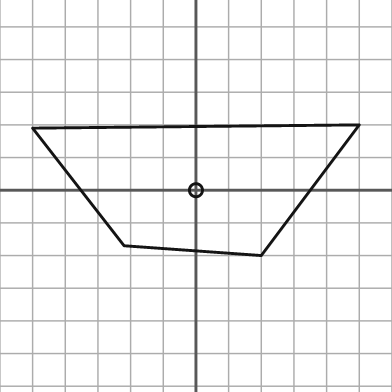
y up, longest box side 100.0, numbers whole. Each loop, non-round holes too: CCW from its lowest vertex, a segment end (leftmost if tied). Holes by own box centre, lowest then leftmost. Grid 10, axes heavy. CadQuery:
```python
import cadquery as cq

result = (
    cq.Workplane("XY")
    .moveTo(20.0, -20.0)
    .lineTo(50.0, 20.0)
    .lineTo(-50.0, 19.0)
    .lineTo(-22.0, -17.0)
    .close()
    .moveTo(0.0, 0.0)
    .circle(2.0)
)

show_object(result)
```